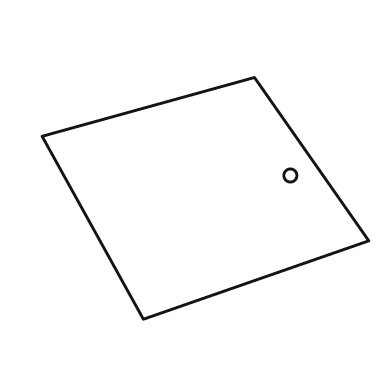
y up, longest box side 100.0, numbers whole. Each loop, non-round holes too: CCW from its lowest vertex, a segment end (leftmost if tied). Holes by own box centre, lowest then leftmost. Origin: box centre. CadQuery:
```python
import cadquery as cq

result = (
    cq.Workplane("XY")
    .moveTo(-19.0, -37.0)
    .lineTo(50.0, -13.0)
    .lineTo(15.0, 37.0)
    .lineTo(-50.0, 19.0)
    .close()
    .moveTo(26.0, 7.0)
    .circle(2.0)
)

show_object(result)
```